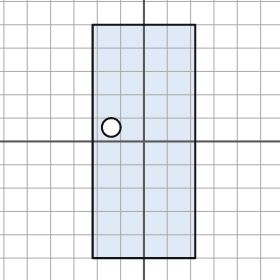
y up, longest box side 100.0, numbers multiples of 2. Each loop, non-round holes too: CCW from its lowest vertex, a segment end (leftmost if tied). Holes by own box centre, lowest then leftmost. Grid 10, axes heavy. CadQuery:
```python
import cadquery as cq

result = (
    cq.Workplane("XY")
    .moveTo(-22.0, -50.0)
    .lineTo(22.0, -50.0)
    .lineTo(22.0, 50.0)
    .lineTo(-22.0, 50.0)
    .close()
    .moveTo(-14.0, 6.0)
    .circle(4.0)
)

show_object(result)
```